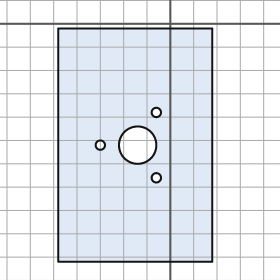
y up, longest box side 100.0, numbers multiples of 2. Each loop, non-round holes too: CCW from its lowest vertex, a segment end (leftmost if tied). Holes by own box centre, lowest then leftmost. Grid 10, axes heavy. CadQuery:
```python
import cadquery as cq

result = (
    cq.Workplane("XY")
    .moveTo(-48.0, -102.0)
    .lineTo(18.0, -102.0)
    .lineTo(18.0, -2.0)
    .lineTo(-48.0, -2.0)
    .close()
    .moveTo(-6.0, -66.0)
    .circle(2.0)
    .moveTo(-30.0, -52.0)
    .circle(2.0)
    .moveTo(-14.0, -52.0)
    .circle(8.0)
    .moveTo(-6.0, -38.0)
    .circle(2.0)
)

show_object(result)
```